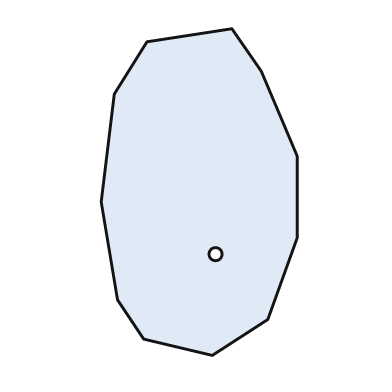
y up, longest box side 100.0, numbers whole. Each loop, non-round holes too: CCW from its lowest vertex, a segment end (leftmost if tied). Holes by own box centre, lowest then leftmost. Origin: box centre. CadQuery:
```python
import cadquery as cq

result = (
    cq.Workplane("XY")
    .moveTo(4.0, -50.0)
    .lineTo(21.0, -39.0)
    .lineTo(30.0, -14.0)
    .lineTo(30.0, 11.0)
    .lineTo(19.0, 37.0)
    .lineTo(10.0, 50.0)
    .lineTo(-16.0, 46.0)
    .lineTo(-26.0, 30.0)
    .lineTo(-30.0, -3.0)
    .lineTo(-25.0, -33.0)
    .lineTo(-17.0, -45.0)
    .close()
    .moveTo(5.0, -19.0)
    .circle(2.0)
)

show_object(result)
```